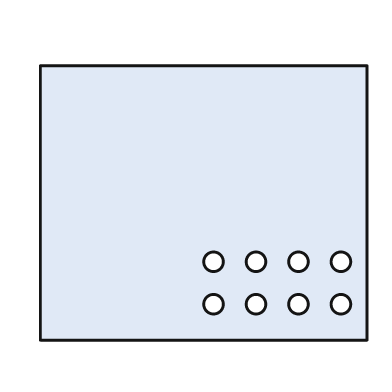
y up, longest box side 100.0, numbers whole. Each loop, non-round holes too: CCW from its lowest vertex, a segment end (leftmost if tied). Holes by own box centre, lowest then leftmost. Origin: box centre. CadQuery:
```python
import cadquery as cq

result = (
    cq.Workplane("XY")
    .moveTo(-50.0, -42.0)
    .lineTo(50.0, -42.0)
    .lineTo(50.0, 42.0)
    .lineTo(-50.0, 42.0)
    .close()
    .moveTo(3.0, -31.0)
    .circle(3.0)
    .moveTo(16.0, -31.0)
    .circle(3.0)
    .moveTo(29.0, -31.0)
    .circle(3.0)
    .moveTo(42.0, -31.0)
    .circle(3.0)
    .moveTo(3.0, -18.0)
    .circle(3.0)
    .moveTo(16.0, -18.0)
    .circle(3.0)
    .moveTo(29.0, -18.0)
    .circle(3.0)
    .moveTo(42.0, -18.0)
    .circle(3.0)
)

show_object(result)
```